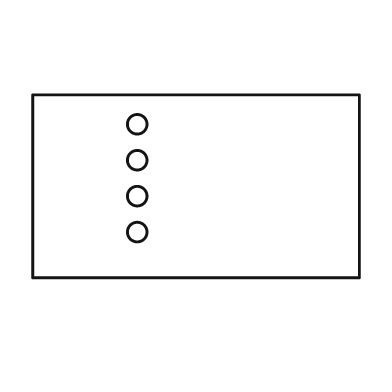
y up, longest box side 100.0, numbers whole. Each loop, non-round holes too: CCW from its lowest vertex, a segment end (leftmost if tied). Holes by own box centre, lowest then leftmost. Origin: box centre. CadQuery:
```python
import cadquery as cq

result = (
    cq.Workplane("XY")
    .moveTo(-50.0, -28.0)
    .lineTo(50.0, -28.0)
    .lineTo(50.0, 28.0)
    .lineTo(-50.0, 28.0)
    .close()
    .moveTo(-18.0, -14.0)
    .circle(3.0)
    .moveTo(-18.0, -3.0)
    .circle(3.0)
    .moveTo(-18.0, 8.0)
    .circle(3.0)
    .moveTo(-18.0, 19.0)
    .circle(3.0)
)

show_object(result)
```